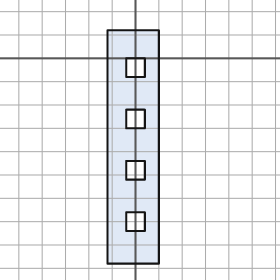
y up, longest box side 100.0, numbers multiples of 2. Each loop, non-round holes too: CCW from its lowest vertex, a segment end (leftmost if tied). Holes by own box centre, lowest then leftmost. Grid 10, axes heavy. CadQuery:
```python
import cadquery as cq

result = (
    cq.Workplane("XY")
    .moveTo(-12.0, -88.0)
    .lineTo(10.0, -88.0)
    .lineTo(10.0, 12.0)
    .lineTo(-12.0, 12.0)
    .close()
    .moveTo(-4.0, -74.0)
    .lineTo(4.0, -74.0)
    .lineTo(4.0, -66.0)
    .lineTo(-4.0, -66.0)
    .close()
    .moveTo(-4.0, -52.0)
    .lineTo(4.0, -52.0)
    .lineTo(4.0, -44.0)
    .lineTo(-4.0, -44.0)
    .close()
    .moveTo(-4.0, -30.0)
    .lineTo(4.0, -30.0)
    .lineTo(4.0, -22.0)
    .lineTo(-4.0, -22.0)
    .close()
    .moveTo(-4.0, -8.0)
    .lineTo(4.0, -8.0)
    .lineTo(4.0, 0.0)
    .lineTo(-4.0, 0.0)
    .close()
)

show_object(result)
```